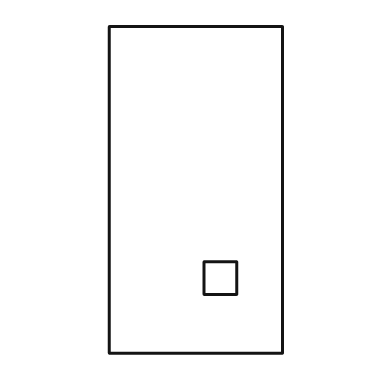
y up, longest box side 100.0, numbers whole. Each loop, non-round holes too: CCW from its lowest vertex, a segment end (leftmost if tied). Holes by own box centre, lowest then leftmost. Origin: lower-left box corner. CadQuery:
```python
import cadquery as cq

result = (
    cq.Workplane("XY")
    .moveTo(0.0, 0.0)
    .lineTo(53.0, 0.0)
    .lineTo(53.0, 100.0)
    .lineTo(0.0, 100.0)
    .close()
    .moveTo(29.0, 18.0)
    .lineTo(39.0, 18.0)
    .lineTo(39.0, 28.0)
    .lineTo(29.0, 28.0)
    .close()
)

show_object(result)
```